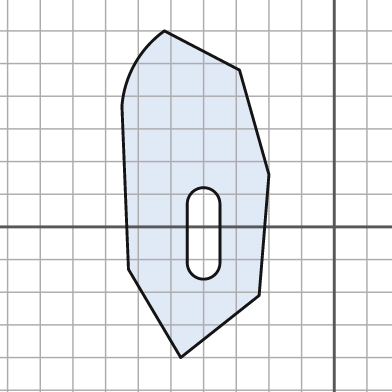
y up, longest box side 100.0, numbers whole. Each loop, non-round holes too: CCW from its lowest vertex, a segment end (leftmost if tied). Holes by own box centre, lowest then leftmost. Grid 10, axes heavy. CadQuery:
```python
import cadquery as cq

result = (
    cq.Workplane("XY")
    .moveTo(-47.0, -40.0)
    .lineTo(-23.0, -21.0)
    .lineTo(-20.0, 16.0)
    .lineTo(-29.0, 48.0)
    .lineTo(-52.0, 60.0)
    .threePointArc((-61.0, 50.0), (-65.0, 37.0))
    .lineTo(-63.0, -13.0)
    .close()
    .moveTo(-45.0, -11.0)
    .threePointArc((-40.0, -16.0), (-35.0, -11.0))
    .lineTo(-35.0, 7.0)
    .threePointArc((-40.0, 12.0), (-45.0, 7.0))
    .close()
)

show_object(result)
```